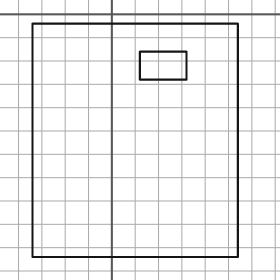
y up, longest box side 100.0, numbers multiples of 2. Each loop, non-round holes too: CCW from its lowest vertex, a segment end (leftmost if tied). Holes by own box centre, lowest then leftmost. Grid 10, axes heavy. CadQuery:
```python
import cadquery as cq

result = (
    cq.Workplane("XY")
    .moveTo(-34.0, -104.0)
    .lineTo(54.0, -104.0)
    .lineTo(54.0, -4.0)
    .lineTo(-34.0, -4.0)
    .close()
    .moveTo(12.0, -28.0)
    .lineTo(32.0, -28.0)
    .lineTo(32.0, -16.0)
    .lineTo(12.0, -16.0)
    .close()
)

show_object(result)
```